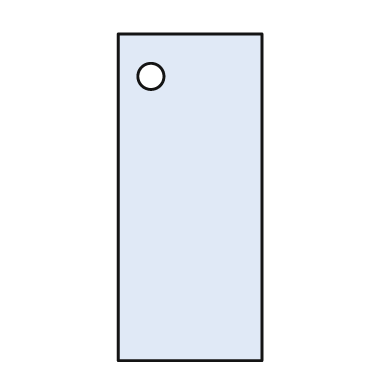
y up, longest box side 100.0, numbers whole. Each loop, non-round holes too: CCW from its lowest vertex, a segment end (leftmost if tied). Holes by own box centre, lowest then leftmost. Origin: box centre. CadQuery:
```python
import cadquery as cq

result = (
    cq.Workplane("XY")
    .moveTo(-22.0, -50.0)
    .lineTo(22.0, -50.0)
    .lineTo(22.0, 50.0)
    .lineTo(-22.0, 50.0)
    .close()
    .moveTo(-12.0, 37.0)
    .circle(4.0)
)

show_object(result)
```